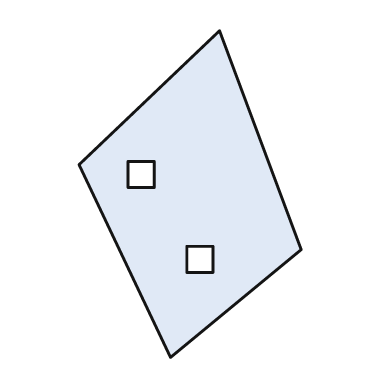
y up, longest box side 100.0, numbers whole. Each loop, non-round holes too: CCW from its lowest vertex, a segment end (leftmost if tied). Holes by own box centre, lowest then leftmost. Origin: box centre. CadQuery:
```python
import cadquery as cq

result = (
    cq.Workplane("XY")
    .moveTo(-6.0, -50.0)
    .lineTo(34.0, -17.0)
    .lineTo(9.0, 50.0)
    .lineTo(-34.0, 9.0)
    .close()
    .moveTo(-1.0, -24.0)
    .lineTo(7.0, -24.0)
    .lineTo(7.0, -16.0)
    .lineTo(-1.0, -16.0)
    .close()
    .moveTo(-19.0, 2.0)
    .lineTo(-11.0, 2.0)
    .lineTo(-11.0, 10.0)
    .lineTo(-19.0, 10.0)
    .close()
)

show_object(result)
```